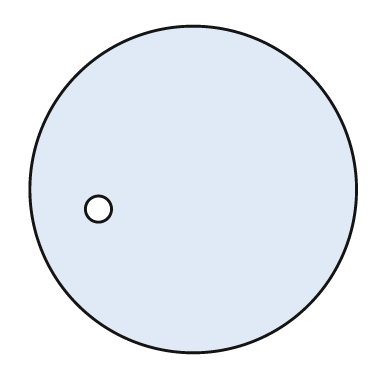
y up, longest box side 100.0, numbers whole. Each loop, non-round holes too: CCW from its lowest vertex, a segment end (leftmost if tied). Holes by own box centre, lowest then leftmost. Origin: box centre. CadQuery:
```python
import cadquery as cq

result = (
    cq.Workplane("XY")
    .moveTo(0.0, 0.0)
    .circle(50.0)
    .moveTo(-29.0, -6.0)
    .circle(4.0)
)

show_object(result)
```